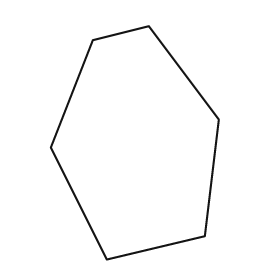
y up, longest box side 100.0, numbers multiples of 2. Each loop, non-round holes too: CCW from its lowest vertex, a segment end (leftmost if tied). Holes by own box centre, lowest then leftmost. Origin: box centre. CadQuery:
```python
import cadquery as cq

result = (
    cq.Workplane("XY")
    .moveTo(-12.0, -50.0)
    .lineTo(30.0, -40.0)
    .lineTo(36.0, 10.0)
    .lineTo(6.0, 50.0)
    .lineTo(-18.0, 44.0)
    .lineTo(-36.0, -2.0)
    .close()
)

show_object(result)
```